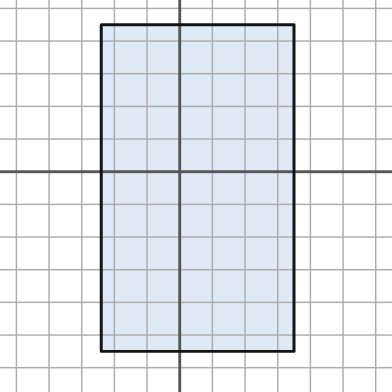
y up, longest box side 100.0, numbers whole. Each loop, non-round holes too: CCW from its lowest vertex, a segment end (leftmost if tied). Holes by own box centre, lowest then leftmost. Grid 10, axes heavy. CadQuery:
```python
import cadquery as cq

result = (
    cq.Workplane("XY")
    .moveTo(-24.0, -55.0)
    .lineTo(35.0, -55.0)
    .lineTo(35.0, 45.0)
    .lineTo(-24.0, 45.0)
    .close()
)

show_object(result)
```